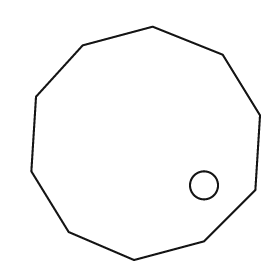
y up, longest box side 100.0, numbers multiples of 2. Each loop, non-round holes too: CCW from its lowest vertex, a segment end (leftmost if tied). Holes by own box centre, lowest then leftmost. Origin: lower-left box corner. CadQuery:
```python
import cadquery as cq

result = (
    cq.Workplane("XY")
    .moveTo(44.0, 0.0)
    .lineTo(74.0, 8.0)
    .lineTo(96.0, 30.0)
    .lineTo(98.0, 62.0)
    .lineTo(82.0, 88.0)
    .lineTo(52.0, 100.0)
    .lineTo(22.0, 92.0)
    .lineTo(2.0, 70.0)
    .lineTo(0.0, 38.0)
    .lineTo(16.0, 12.0)
    .close()
    .moveTo(74.0, 32.0)
    .circle(6.0)
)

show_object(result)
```